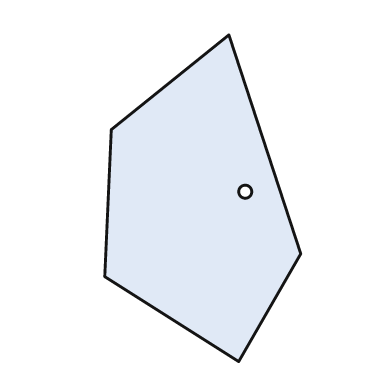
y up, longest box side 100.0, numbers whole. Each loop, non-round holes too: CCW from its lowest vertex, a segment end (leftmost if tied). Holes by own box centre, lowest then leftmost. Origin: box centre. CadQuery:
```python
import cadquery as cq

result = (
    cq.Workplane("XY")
    .moveTo(11.0, -50.0)
    .lineTo(30.0, -17.0)
    .lineTo(8.0, 50.0)
    .lineTo(-28.0, 21.0)
    .lineTo(-30.0, -24.0)
    .close()
    .moveTo(13.0, 2.0)
    .circle(2.0)
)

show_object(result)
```